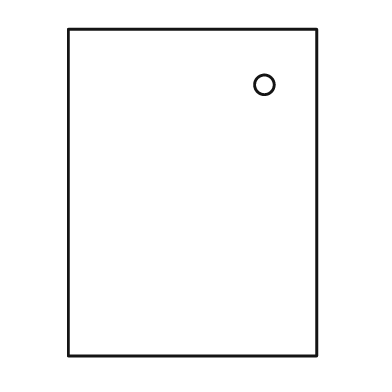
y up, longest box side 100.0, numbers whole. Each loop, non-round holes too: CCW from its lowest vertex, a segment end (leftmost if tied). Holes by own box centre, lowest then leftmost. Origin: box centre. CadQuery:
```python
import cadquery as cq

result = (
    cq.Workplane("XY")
    .moveTo(-38.0, -50.0)
    .lineTo(38.0, -50.0)
    .lineTo(38.0, 50.0)
    .lineTo(-38.0, 50.0)
    .close()
    .moveTo(22.0, 33.0)
    .circle(3.0)
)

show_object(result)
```